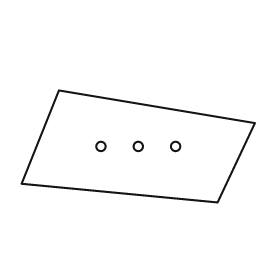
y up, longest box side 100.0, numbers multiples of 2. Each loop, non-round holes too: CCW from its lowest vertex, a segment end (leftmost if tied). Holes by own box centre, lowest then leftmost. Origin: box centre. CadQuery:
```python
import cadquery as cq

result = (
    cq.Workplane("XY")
    .moveTo(34.0, -24.0)
    .lineTo(50.0, 10.0)
    .lineTo(-34.0, 24.0)
    .lineTo(-50.0, -16.0)
    .close()
    .moveTo(-16.0, 0.0)
    .circle(2.0)
    .moveTo(0.0, 0.0)
    .circle(2.0)
    .moveTo(16.0, 0.0)
    .circle(2.0)
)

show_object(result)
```